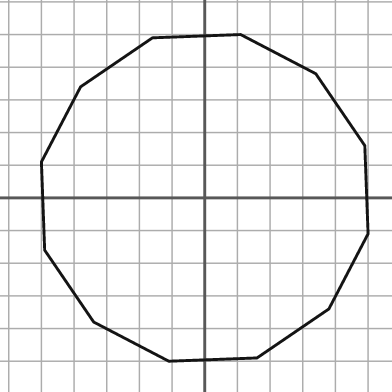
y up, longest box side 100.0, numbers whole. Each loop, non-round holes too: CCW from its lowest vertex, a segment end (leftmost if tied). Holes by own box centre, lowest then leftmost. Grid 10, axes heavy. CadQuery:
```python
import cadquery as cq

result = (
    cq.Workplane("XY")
    .moveTo(-11.0, -50.0)
    .lineTo(16.0, -49.0)
    .lineTo(38.0, -34.0)
    .lineTo(50.0, -11.0)
    .lineTo(49.0, 16.0)
    .lineTo(34.0, 38.0)
    .lineTo(11.0, 50.0)
    .lineTo(-16.0, 49.0)
    .lineTo(-38.0, 34.0)
    .lineTo(-50.0, 11.0)
    .lineTo(-49.0, -16.0)
    .lineTo(-34.0, -38.0)
    .close()
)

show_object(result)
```